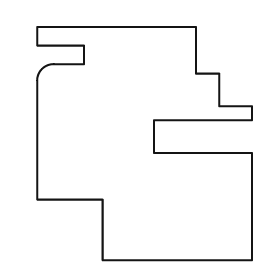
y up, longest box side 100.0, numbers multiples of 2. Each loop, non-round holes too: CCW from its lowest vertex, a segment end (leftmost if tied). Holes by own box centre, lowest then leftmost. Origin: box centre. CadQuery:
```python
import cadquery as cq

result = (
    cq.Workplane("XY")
    .moveTo(-18.0, -50.0)
    .lineTo(46.0, -50.0)
    .lineTo(46.0, -4.0)
    .lineTo(4.0, -4.0)
    .lineTo(4.0, 10.0)
    .lineTo(46.0, 10.0)
    .lineTo(46.0, 16.0)
    .lineTo(32.0, 16.0)
    .lineTo(32.0, 30.0)
    .lineTo(22.0, 30.0)
    .lineTo(22.0, 50.0)
    .lineTo(-46.0, 50.0)
    .lineTo(-46.0, 42.0)
    .lineTo(-26.0, 42.0)
    .lineTo(-26.0, 34.0)
    .lineTo(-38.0, 34.0)
    .threePointArc((-44.0, 32.0), (-46.0, 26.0))
    .lineTo(-46.0, -24.0)
    .lineTo(-18.0, -24.0)
    .close()
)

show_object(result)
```